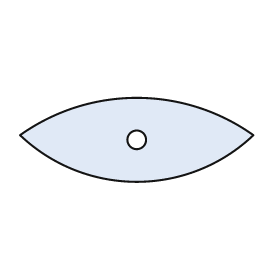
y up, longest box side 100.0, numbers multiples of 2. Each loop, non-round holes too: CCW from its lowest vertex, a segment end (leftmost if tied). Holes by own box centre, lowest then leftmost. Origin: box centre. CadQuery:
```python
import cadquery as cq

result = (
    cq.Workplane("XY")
    .moveTo(-50.0, 2.0)
    .threePointArc((0.0, -18.0), (50.0, 2.0))
    .threePointArc((0.0, 18.0), (-50.0, 2.0))
    .close()
    .moveTo(0.0, 0.0)
    .circle(4.0)
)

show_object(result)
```